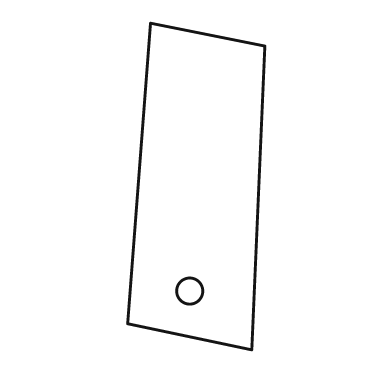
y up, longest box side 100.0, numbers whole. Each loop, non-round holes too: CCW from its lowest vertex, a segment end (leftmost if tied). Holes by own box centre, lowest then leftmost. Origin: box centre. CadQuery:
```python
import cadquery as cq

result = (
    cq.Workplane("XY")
    .moveTo(17.0, -50.0)
    .lineTo(21.0, 43.0)
    .lineTo(-14.0, 50.0)
    .lineTo(-21.0, -42.0)
    .close()
    .moveTo(-2.0, -32.0)
    .circle(4.0)
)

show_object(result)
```